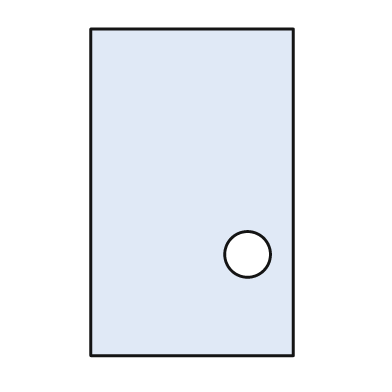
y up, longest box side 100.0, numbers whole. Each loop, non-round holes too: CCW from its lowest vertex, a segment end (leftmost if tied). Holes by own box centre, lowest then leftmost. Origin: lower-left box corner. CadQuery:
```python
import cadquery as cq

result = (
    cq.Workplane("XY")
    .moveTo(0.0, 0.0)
    .lineTo(62.0, 0.0)
    .lineTo(62.0, 100.0)
    .lineTo(0.0, 100.0)
    .close()
    .moveTo(48.0, 31.0)
    .circle(7.0)
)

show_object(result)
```